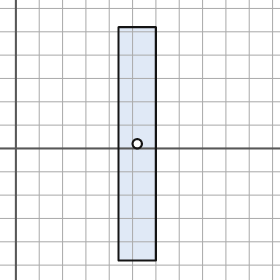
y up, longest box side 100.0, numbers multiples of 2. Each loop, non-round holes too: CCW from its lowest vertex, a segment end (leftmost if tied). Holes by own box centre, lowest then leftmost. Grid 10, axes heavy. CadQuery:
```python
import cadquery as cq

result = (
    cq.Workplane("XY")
    .moveTo(44.0, -48.0)
    .lineTo(60.0, -48.0)
    .lineTo(60.0, 52.0)
    .lineTo(44.0, 52.0)
    .close()
    .moveTo(52.0, 2.0)
    .circle(2.0)
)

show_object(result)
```